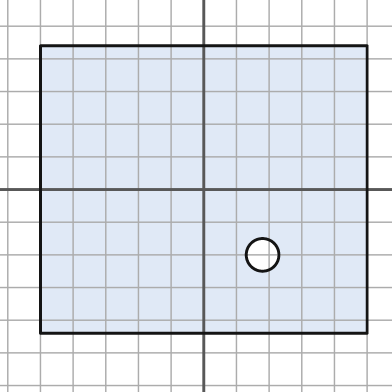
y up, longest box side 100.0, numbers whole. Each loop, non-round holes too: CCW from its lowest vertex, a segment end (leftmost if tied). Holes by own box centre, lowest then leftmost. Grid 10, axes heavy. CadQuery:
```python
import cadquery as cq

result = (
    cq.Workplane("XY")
    .moveTo(-50.0, -44.0)
    .lineTo(50.0, -44.0)
    .lineTo(50.0, 44.0)
    .lineTo(-50.0, 44.0)
    .close()
    .moveTo(18.0, -20.0)
    .circle(5.0)
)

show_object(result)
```